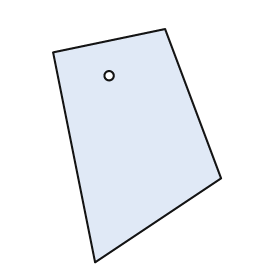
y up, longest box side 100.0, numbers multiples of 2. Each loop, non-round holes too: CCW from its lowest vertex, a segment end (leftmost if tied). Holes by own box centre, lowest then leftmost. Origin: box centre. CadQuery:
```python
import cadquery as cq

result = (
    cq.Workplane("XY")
    .moveTo(-18.0, -50.0)
    .lineTo(36.0, -14.0)
    .lineTo(12.0, 50.0)
    .lineTo(-36.0, 40.0)
    .close()
    .moveTo(-12.0, 30.0)
    .circle(2.0)
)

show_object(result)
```